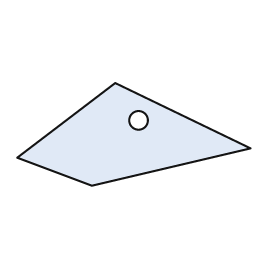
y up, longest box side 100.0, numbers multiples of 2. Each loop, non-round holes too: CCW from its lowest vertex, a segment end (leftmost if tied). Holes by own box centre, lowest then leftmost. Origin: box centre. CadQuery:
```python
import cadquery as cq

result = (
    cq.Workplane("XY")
    .moveTo(-18.0, -22.0)
    .lineTo(50.0, -6.0)
    .lineTo(-8.0, 22.0)
    .lineTo(-50.0, -10.0)
    .close()
    .moveTo(2.0, 6.0)
    .circle(4.0)
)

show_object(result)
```